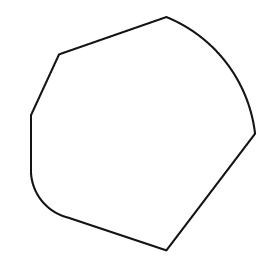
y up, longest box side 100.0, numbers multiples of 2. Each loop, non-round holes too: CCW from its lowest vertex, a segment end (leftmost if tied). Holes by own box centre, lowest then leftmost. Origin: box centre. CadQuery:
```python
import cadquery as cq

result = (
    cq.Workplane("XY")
    .moveTo(10.0, -50.0)
    .lineTo(48.0, 0.0)
    .threePointArc((36.0, 30.0), (10.0, 50.0))
    .lineTo(-36.0, 34.0)
    .lineTo(-48.0, 8.0)
    .lineTo(-48.0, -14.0)
    .threePointArc((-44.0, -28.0), (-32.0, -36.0))
    .close()
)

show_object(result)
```